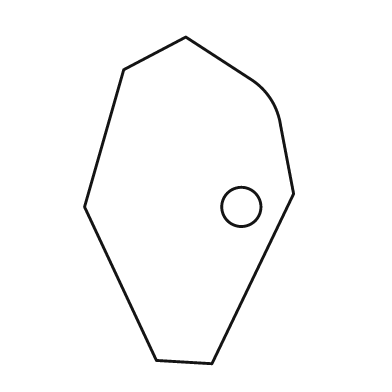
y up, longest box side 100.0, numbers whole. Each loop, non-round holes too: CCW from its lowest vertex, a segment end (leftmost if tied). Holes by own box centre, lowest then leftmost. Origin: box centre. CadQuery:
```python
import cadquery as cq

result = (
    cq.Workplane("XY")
    .moveTo(7.0, -50.0)
    .lineTo(32.0, 2.0)
    .lineTo(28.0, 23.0)
    .threePointArc((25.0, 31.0), (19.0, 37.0))
    .lineTo(-1.0, 50.0)
    .lineTo(-20.0, 40.0)
    .lineTo(-32.0, -2.0)
    .lineTo(-10.0, -49.0)
    .close()
    .moveTo(16.0, -2.0)
    .circle(6.0)
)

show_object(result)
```